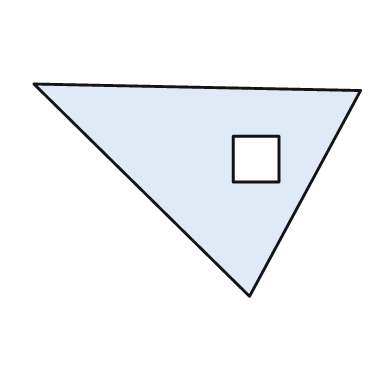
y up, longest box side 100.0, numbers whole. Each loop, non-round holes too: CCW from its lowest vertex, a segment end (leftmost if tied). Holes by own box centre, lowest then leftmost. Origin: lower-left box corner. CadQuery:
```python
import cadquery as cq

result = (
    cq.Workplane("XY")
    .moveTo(66.0, 0.0)
    .lineTo(100.0, 63.0)
    .lineTo(0.0, 65.0)
    .close()
    .moveTo(61.0, 35.0)
    .lineTo(75.0, 35.0)
    .lineTo(75.0, 49.0)
    .lineTo(61.0, 49.0)
    .close()
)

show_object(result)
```